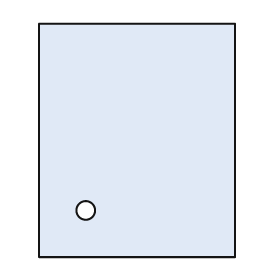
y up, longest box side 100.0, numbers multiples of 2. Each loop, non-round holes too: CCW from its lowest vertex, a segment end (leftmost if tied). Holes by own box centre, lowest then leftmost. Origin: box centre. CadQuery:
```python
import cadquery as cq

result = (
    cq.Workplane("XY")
    .moveTo(-42.0, -50.0)
    .lineTo(42.0, -50.0)
    .lineTo(42.0, 50.0)
    .lineTo(-42.0, 50.0)
    .close()
    .moveTo(-22.0, -30.0)
    .circle(4.0)
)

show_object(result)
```